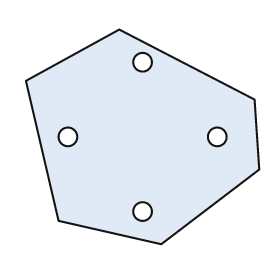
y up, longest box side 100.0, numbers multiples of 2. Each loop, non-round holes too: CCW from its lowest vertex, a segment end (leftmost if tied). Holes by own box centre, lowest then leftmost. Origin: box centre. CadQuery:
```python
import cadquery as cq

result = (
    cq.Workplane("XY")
    .moveTo(8.0, -46.0)
    .lineTo(50.0, -14.0)
    .lineTo(48.0, 16.0)
    .lineTo(-10.0, 46.0)
    .lineTo(-50.0, 24.0)
    .lineTo(-36.0, -36.0)
    .close()
    .moveTo(0.0, -32.0)
    .circle(4.0)
    .moveTo(-32.0, 0.0)
    .circle(4.0)
    .moveTo(32.0, 0.0)
    .circle(4.0)
    .moveTo(0.0, 32.0)
    .circle(4.0)
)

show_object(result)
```